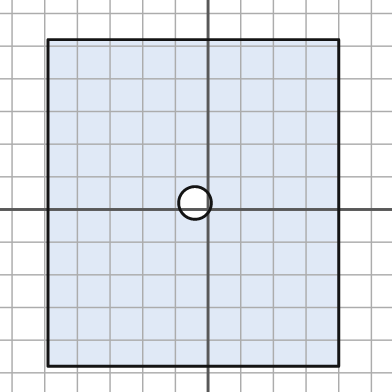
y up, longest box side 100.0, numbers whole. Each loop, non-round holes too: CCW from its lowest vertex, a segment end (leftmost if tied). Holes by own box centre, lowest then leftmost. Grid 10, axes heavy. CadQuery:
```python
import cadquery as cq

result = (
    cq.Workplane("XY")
    .moveTo(-49.0, -48.0)
    .lineTo(40.0, -48.0)
    .lineTo(40.0, 52.0)
    .lineTo(-49.0, 52.0)
    .close()
    .moveTo(-4.0, 2.0)
    .circle(5.0)
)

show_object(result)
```